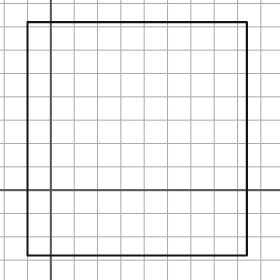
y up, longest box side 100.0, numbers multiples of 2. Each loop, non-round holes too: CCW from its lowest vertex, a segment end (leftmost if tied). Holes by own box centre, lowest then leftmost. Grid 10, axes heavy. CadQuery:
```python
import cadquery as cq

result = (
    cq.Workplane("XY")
    .moveTo(-10.0, -28.0)
    .lineTo(84.0, -28.0)
    .lineTo(84.0, 72.0)
    .lineTo(-10.0, 72.0)
    .close()
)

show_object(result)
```